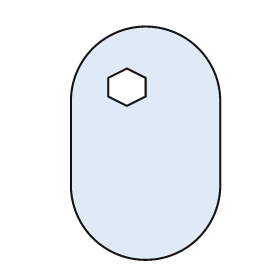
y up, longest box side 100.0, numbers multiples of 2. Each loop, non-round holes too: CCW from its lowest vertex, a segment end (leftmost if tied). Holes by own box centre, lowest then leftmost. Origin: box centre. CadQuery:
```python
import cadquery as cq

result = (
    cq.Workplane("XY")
    .moveTo(-32.0, -18.0)
    .threePointArc((0.0, -50.0), (32.0, -18.0))
    .lineTo(32.0, 18.0)
    .threePointArc((0.0, 50.0), (-32.0, 18.0))
    .close()
    .moveTo(-8.0, 16.0)
    .lineTo(0.0, 20.0)
    .lineTo(0.0, 28.0)
    .lineTo(-8.0, 32.0)
    .lineTo(-16.0, 28.0)
    .lineTo(-16.0, 20.0)
    .close()
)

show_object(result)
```